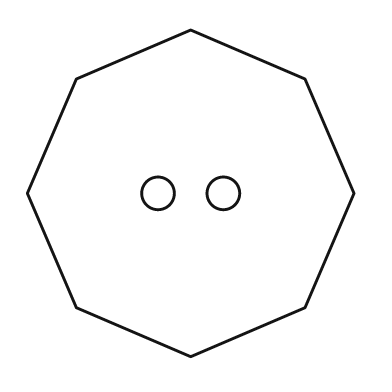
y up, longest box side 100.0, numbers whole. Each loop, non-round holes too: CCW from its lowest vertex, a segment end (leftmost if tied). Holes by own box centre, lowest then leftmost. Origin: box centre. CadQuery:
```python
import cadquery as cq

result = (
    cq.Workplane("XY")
    .moveTo(0.0, -50.0)
    .lineTo(35.0, -35.0)
    .lineTo(50.0, 0.0)
    .lineTo(35.0, 35.0)
    .lineTo(0.0, 50.0)
    .lineTo(-35.0, 35.0)
    .lineTo(-50.0, 0.0)
    .lineTo(-35.0, -35.0)
    .close()
    .moveTo(-10.0, 0.0)
    .circle(5.0)
    .moveTo(10.0, 0.0)
    .circle(5.0)
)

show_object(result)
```